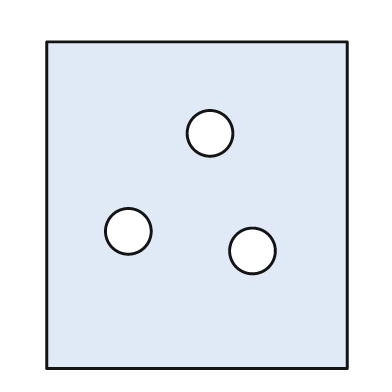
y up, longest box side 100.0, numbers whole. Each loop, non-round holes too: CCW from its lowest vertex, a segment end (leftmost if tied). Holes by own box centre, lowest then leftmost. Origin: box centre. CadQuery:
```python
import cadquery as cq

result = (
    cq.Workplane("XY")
    .moveTo(-46.0, -50.0)
    .lineTo(46.0, -50.0)
    .lineTo(46.0, 50.0)
    .lineTo(-46.0, 50.0)
    .close()
    .moveTo(17.0, -14.0)
    .circle(7.0)
    .moveTo(-21.0, -8.0)
    .circle(7.0)
    .moveTo(4.0, 22.0)
    .circle(7.0)
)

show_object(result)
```